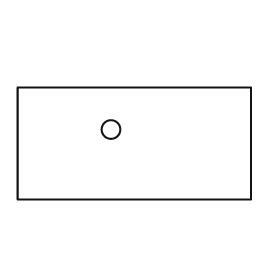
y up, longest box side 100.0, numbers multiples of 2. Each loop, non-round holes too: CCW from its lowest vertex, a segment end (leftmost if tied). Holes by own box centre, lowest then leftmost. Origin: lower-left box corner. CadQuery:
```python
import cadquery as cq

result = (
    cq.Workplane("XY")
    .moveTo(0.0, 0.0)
    .lineTo(100.0, 0.0)
    .lineTo(100.0, 48.0)
    .lineTo(0.0, 48.0)
    .close()
    .moveTo(40.0, 30.0)
    .circle(4.0)
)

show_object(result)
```